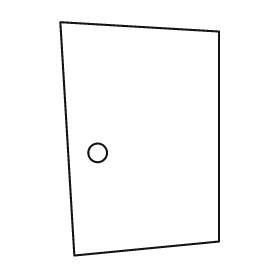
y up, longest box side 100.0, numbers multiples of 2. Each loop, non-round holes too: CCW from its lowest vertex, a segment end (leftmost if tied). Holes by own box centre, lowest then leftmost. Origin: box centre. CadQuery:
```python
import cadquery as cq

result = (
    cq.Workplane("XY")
    .moveTo(-28.0, -50.0)
    .lineTo(34.0, -44.0)
    .lineTo(34.0, 46.0)
    .lineTo(-34.0, 50.0)
    .close()
    .moveTo(-18.0, -6.0)
    .circle(4.0)
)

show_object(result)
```